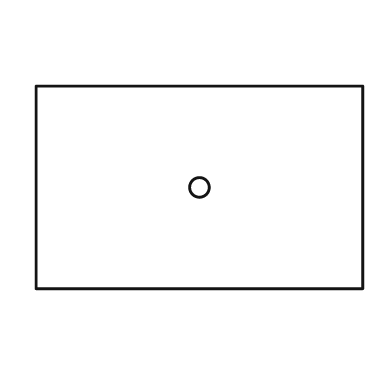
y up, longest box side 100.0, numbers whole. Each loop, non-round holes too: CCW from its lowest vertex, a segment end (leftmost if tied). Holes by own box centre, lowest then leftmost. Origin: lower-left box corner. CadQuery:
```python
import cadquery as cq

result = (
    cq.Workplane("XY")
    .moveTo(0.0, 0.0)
    .lineTo(100.0, 0.0)
    .lineTo(100.0, 62.0)
    .lineTo(0.0, 62.0)
    .close()
    .moveTo(50.0, 31.0)
    .circle(3.0)
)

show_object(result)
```